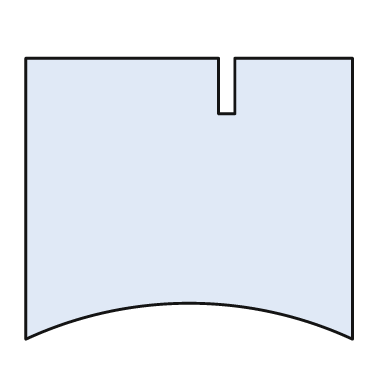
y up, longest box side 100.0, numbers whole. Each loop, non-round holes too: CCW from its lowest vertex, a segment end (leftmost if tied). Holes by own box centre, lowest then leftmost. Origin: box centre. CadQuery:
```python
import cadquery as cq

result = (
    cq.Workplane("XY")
    .moveTo(-50.0, -43.0)
    .threePointArc((0.0, -32.0), (50.0, -43.0))
    .lineTo(50.0, 43.0)
    .lineTo(14.0, 43.0)
    .lineTo(14.0, 26.0)
    .lineTo(9.0, 26.0)
    .lineTo(9.0, 43.0)
    .lineTo(-50.0, 43.0)
    .close()
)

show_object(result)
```